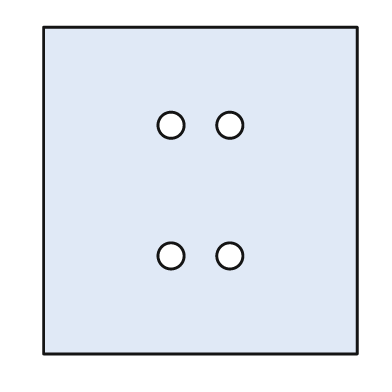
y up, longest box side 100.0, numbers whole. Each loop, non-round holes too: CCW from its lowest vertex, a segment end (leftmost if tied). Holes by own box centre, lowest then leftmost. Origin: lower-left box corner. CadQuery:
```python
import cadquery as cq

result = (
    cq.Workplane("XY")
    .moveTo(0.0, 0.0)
    .lineTo(96.0, 0.0)
    .lineTo(96.0, 100.0)
    .lineTo(0.0, 100.0)
    .close()
    .moveTo(39.0, 30.0)
    .circle(4.0)
    .moveTo(57.0, 30.0)
    .circle(4.0)
    .moveTo(39.0, 70.0)
    .circle(4.0)
    .moveTo(57.0, 70.0)
    .circle(4.0)
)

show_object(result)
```